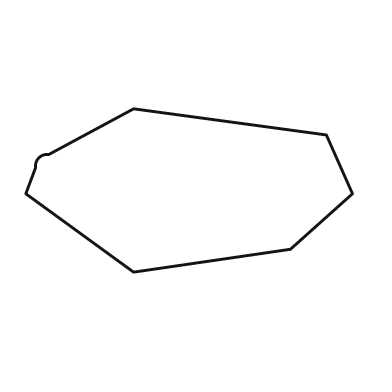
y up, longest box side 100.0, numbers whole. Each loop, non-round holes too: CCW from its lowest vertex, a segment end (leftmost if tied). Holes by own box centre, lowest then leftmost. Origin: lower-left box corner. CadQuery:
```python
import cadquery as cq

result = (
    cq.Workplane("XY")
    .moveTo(33.0, 0.0)
    .lineTo(81.0, 7.0)
    .lineTo(100.0, 24.0)
    .lineTo(92.0, 42.0)
    .lineTo(33.0, 50.0)
    .lineTo(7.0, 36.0)
    .threePointArc((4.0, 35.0), (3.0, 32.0))
    .lineTo(0.0, 24.0)
    .close()
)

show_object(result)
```